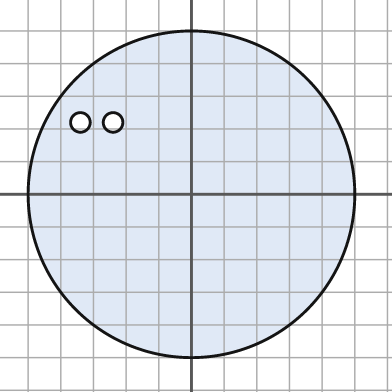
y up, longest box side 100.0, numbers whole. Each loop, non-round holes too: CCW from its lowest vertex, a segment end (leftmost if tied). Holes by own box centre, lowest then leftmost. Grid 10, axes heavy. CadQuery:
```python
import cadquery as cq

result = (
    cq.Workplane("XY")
    .moveTo(0.0, 0.0)
    .circle(50.0)
    .moveTo(-34.0, 22.0)
    .circle(3.0)
    .moveTo(-24.0, 22.0)
    .circle(3.0)
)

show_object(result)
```